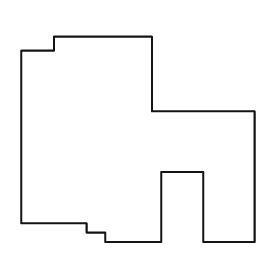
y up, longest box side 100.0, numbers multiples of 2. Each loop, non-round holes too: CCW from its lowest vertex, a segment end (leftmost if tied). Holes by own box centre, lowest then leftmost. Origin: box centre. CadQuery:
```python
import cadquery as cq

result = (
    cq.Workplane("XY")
    .moveTo(-14.0, -44.0)
    .lineTo(10.0, -44.0)
    .lineTo(10.0, -14.0)
    .lineTo(28.0, -14.0)
    .lineTo(28.0, -44.0)
    .lineTo(50.0, -44.0)
    .lineTo(50.0, 12.0)
    .lineTo(6.0, 12.0)
    .lineTo(6.0, 44.0)
    .lineTo(-36.0, 44.0)
    .lineTo(-36.0, 38.0)
    .lineTo(-50.0, 38.0)
    .lineTo(-50.0, -36.0)
    .lineTo(-22.0, -36.0)
    .lineTo(-22.0, -40.0)
    .lineTo(-14.0, -40.0)
    .close()
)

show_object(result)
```